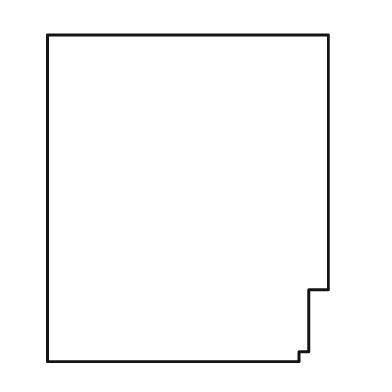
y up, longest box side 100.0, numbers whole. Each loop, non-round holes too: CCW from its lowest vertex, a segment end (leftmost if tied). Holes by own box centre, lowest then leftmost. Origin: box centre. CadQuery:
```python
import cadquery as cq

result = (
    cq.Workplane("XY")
    .moveTo(-43.0, -50.0)
    .lineTo(34.0, -50.0)
    .lineTo(34.0, -47.0)
    .lineTo(37.0, -47.0)
    .lineTo(37.0, -28.0)
    .lineTo(43.0, -28.0)
    .lineTo(43.0, 50.0)
    .lineTo(-43.0, 50.0)
    .close()
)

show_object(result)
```